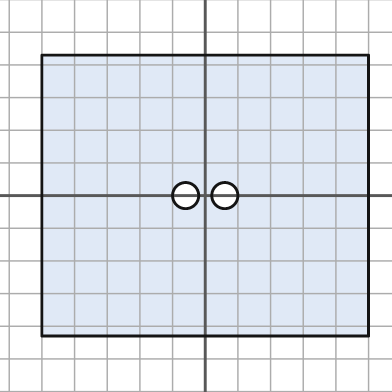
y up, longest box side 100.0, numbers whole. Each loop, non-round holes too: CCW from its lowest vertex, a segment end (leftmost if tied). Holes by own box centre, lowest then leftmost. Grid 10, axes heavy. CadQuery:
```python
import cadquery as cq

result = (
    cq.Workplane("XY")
    .moveTo(-50.0, -43.0)
    .lineTo(50.0, -43.0)
    .lineTo(50.0, 43.0)
    .lineTo(-50.0, 43.0)
    .close()
    .moveTo(-6.0, 0.0)
    .circle(4.0)
    .moveTo(6.0, 0.0)
    .circle(4.0)
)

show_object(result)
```